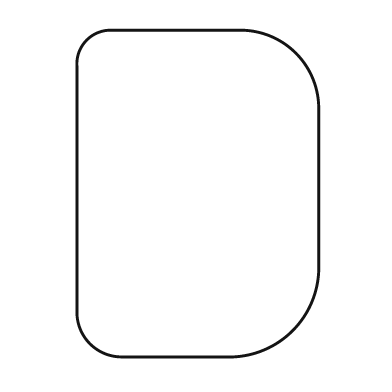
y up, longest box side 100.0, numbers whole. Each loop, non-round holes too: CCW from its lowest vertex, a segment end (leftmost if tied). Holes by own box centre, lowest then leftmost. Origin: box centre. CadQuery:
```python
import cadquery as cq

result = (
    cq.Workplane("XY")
    .moveTo(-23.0, -50.0)
    .lineTo(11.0, -50.0)
    .threePointArc((29.0, -42.0), (37.0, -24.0))
    .lineTo(37.0, 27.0)
    .threePointArc((30.0, 43.0), (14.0, 50.0))
    .lineTo(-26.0, 50.0)
    .threePointArc((-34.0, 47.0), (-37.0, 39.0))
    .lineTo(-37.0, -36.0)
    .threePointArc((-33.0, -46.0), (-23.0, -50.0))
    .close()
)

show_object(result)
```